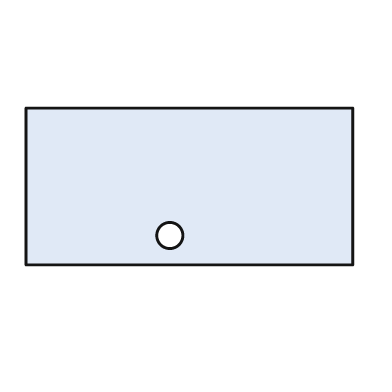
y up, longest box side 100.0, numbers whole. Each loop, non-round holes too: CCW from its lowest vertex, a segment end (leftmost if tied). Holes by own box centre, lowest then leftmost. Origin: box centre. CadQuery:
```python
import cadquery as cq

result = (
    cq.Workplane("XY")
    .moveTo(-50.0, -24.0)
    .lineTo(50.0, -24.0)
    .lineTo(50.0, 24.0)
    .lineTo(-50.0, 24.0)
    .close()
    .moveTo(-6.0, -15.0)
    .circle(4.0)
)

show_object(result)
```